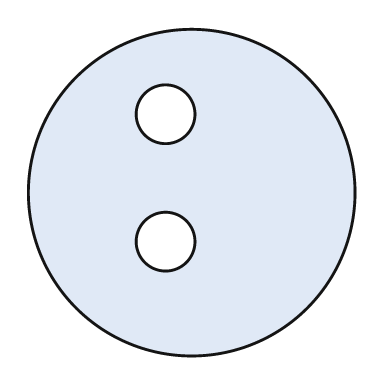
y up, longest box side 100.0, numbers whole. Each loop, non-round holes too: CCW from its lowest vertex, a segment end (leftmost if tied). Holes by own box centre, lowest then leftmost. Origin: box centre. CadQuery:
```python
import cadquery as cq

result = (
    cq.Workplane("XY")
    .moveTo(0.0, 0.0)
    .circle(50.0)
    .moveTo(-8.0, -15.0)
    .circle(9.0)
    .moveTo(-8.0, 24.0)
    .circle(9.0)
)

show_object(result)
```